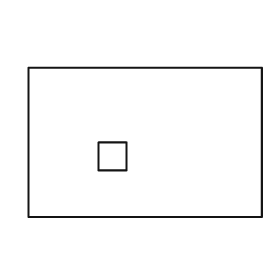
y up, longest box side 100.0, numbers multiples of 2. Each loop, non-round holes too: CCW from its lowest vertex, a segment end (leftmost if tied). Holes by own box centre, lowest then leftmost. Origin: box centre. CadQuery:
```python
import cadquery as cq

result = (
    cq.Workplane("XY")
    .moveTo(-50.0, -32.0)
    .lineTo(50.0, -32.0)
    .lineTo(50.0, 32.0)
    .lineTo(-50.0, 32.0)
    .close()
    .moveTo(-20.0, -12.0)
    .lineTo(-8.0, -12.0)
    .lineTo(-8.0, 0.0)
    .lineTo(-20.0, 0.0)
    .close()
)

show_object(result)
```